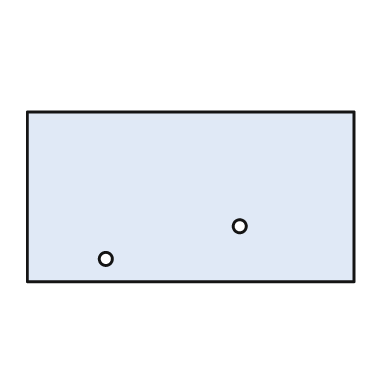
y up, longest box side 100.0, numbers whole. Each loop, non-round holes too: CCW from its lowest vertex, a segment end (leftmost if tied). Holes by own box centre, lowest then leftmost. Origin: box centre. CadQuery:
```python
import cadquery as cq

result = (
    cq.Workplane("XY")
    .moveTo(-50.0, -26.0)
    .lineTo(50.0, -26.0)
    .lineTo(50.0, 26.0)
    .lineTo(-50.0, 26.0)
    .close()
    .moveTo(-26.0, -19.0)
    .circle(2.0)
    .moveTo(15.0, -9.0)
    .circle(2.0)
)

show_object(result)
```